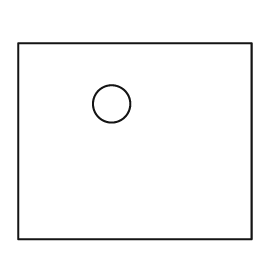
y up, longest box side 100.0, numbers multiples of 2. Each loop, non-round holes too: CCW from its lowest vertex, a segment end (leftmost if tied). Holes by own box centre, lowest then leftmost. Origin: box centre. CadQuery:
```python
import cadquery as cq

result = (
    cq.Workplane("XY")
    .moveTo(-50.0, -42.0)
    .lineTo(50.0, -42.0)
    .lineTo(50.0, 42.0)
    .lineTo(-50.0, 42.0)
    .close()
    .moveTo(-10.0, 16.0)
    .circle(8.0)
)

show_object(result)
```